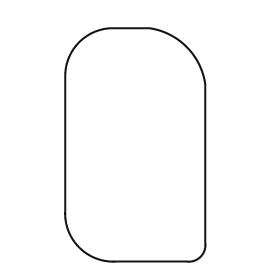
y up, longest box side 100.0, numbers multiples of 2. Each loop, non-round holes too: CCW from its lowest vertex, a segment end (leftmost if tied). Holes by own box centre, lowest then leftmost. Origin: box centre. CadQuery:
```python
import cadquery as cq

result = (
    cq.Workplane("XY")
    .moveTo(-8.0, -50.0)
    .lineTo(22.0, -50.0)
    .threePointArc((28.0, -48.0), (30.0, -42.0))
    .lineTo(30.0, 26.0)
    .threePointArc((22.0, 42.0), (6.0, 50.0))
    .lineTo(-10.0, 50.0)
    .threePointArc((-24.0, 44.0), (-30.0, 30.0))
    .lineTo(-30.0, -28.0)
    .threePointArc((-24.0, -44.0), (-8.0, -50.0))
    .close()
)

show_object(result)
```